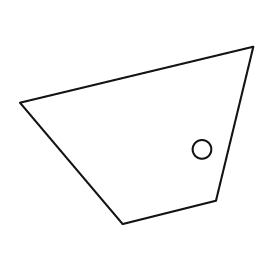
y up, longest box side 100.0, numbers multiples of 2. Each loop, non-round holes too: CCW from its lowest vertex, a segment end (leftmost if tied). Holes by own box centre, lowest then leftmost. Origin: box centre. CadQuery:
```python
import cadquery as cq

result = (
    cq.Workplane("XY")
    .moveTo(-6.0, -38.0)
    .lineTo(34.0, -28.0)
    .lineTo(50.0, 38.0)
    .lineTo(-50.0, 14.0)
    .close()
    .moveTo(28.0, -6.0)
    .circle(4.0)
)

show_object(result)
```